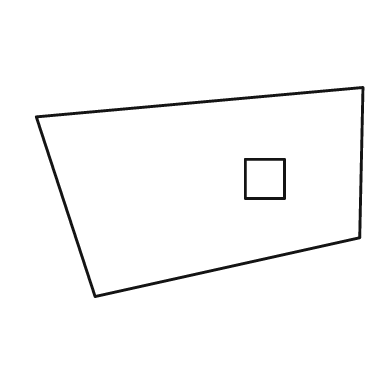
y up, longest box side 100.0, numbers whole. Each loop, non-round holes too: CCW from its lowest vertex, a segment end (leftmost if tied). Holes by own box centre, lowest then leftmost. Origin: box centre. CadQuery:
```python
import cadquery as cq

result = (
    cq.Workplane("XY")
    .moveTo(-32.0, -32.0)
    .lineTo(49.0, -14.0)
    .lineTo(50.0, 32.0)
    .lineTo(-50.0, 23.0)
    .close()
    .moveTo(14.0, -2.0)
    .lineTo(26.0, -2.0)
    .lineTo(26.0, 10.0)
    .lineTo(14.0, 10.0)
    .close()
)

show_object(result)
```